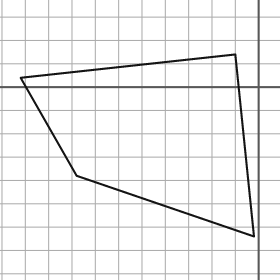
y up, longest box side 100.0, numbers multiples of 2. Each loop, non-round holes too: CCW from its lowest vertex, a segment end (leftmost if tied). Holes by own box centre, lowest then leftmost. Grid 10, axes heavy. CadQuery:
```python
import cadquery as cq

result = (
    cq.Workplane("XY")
    .moveTo(-2.0, -64.0)
    .lineTo(-10.0, 14.0)
    .lineTo(-102.0, 4.0)
    .lineTo(-78.0, -38.0)
    .close()
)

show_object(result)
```